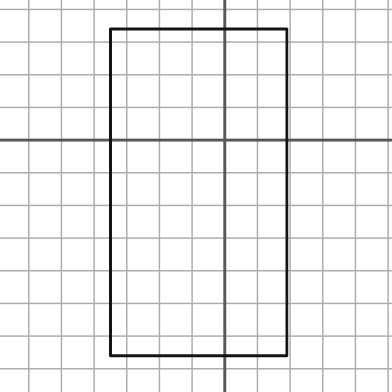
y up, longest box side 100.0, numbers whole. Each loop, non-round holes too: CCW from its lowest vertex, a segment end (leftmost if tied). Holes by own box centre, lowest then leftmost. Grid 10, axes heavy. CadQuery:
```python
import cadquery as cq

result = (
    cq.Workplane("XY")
    .moveTo(-35.0, -66.0)
    .lineTo(19.0, -66.0)
    .lineTo(19.0, 34.0)
    .lineTo(-35.0, 34.0)
    .close()
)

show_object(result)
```